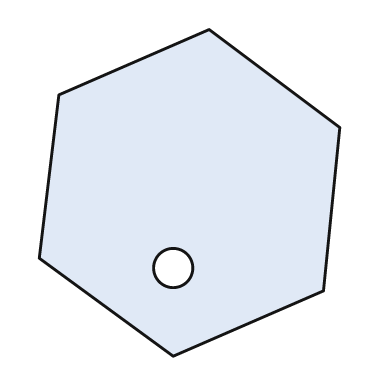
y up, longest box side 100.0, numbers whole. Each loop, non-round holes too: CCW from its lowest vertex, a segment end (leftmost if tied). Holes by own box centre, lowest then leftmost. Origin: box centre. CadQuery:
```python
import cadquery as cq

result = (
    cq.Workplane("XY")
    .moveTo(-5.0, -50.0)
    .lineTo(41.0, -30.0)
    .lineTo(46.0, 20.0)
    .lineTo(6.0, 50.0)
    .lineTo(-40.0, 30.0)
    .lineTo(-46.0, -20.0)
    .close()
    .moveTo(-5.0, -23.0)
    .circle(6.0)
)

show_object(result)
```